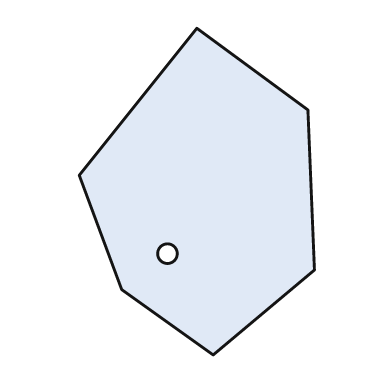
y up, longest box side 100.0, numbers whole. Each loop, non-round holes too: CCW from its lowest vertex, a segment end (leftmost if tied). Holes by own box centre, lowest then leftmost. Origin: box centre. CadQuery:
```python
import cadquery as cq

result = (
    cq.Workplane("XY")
    .moveTo(5.0, -50.0)
    .lineTo(36.0, -24.0)
    .lineTo(34.0, 25.0)
    .lineTo(0.0, 50.0)
    .lineTo(-36.0, 5.0)
    .lineTo(-23.0, -30.0)
    .close()
    .moveTo(-9.0, -19.0)
    .circle(3.0)
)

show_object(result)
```